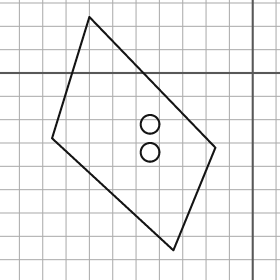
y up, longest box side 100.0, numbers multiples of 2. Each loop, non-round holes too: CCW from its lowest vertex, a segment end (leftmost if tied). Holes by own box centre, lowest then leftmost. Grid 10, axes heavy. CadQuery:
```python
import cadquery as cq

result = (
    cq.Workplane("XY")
    .moveTo(-34.0, -76.0)
    .lineTo(-16.0, -32.0)
    .lineTo(-70.0, 24.0)
    .lineTo(-86.0, -28.0)
    .close()
    .moveTo(-44.0, -34.0)
    .circle(4.0)
    .moveTo(-44.0, -22.0)
    .circle(4.0)
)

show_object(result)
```